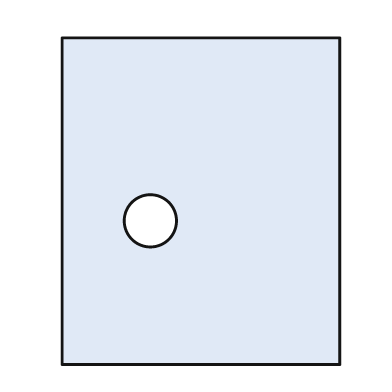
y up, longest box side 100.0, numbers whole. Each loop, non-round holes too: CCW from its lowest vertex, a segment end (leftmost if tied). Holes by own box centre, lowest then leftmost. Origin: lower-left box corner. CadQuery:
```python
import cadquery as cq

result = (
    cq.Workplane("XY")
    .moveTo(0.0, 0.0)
    .lineTo(85.0, 0.0)
    .lineTo(85.0, 100.0)
    .lineTo(0.0, 100.0)
    .close()
    .moveTo(27.0, 44.0)
    .circle(8.0)
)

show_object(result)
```